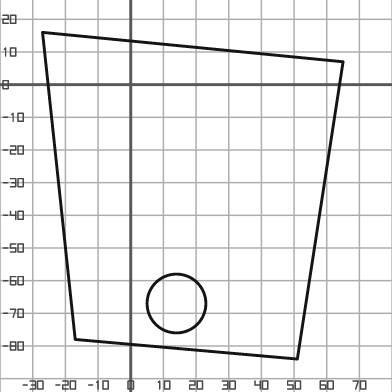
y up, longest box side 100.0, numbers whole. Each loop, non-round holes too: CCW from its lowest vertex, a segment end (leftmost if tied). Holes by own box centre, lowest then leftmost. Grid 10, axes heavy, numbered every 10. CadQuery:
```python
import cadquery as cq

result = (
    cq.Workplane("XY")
    .moveTo(51.0, -84.0)
    .lineTo(65.0, 7.0)
    .lineTo(-27.0, 16.0)
    .lineTo(-17.0, -78.0)
    .close()
    .moveTo(14.0, -67.0)
    .circle(9.0)
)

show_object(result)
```